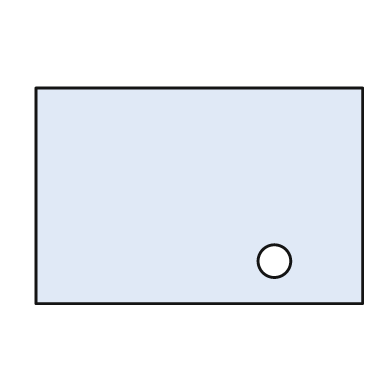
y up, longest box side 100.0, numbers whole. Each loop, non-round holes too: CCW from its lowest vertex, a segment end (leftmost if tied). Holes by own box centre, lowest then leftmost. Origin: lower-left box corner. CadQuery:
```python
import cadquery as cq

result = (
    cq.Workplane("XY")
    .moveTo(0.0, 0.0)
    .lineTo(100.0, 0.0)
    .lineTo(100.0, 66.0)
    .lineTo(0.0, 66.0)
    .close()
    .moveTo(73.0, 13.0)
    .circle(5.0)
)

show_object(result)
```